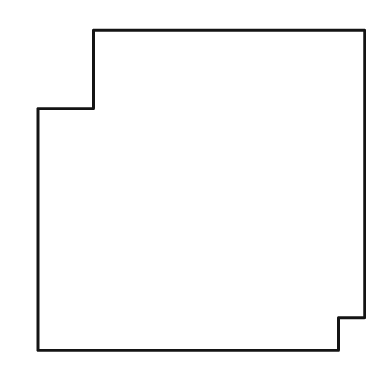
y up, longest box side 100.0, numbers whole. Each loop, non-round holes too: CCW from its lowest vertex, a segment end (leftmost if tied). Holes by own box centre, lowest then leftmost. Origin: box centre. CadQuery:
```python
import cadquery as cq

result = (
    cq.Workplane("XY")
    .moveTo(-50.0, -49.0)
    .lineTo(42.0, -49.0)
    .lineTo(42.0, -39.0)
    .lineTo(50.0, -39.0)
    .lineTo(50.0, 49.0)
    .lineTo(-33.0, 49.0)
    .lineTo(-33.0, 25.0)
    .lineTo(-50.0, 25.0)
    .close()
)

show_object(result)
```